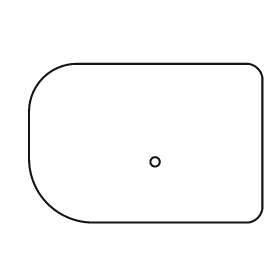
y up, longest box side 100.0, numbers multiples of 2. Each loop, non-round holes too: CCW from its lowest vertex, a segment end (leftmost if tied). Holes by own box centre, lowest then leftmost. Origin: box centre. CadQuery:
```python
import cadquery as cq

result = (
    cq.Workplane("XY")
    .moveTo(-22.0, -34.0)
    .lineTo(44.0, -34.0)
    .threePointArc((48.0, -32.0), (50.0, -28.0))
    .lineTo(50.0, 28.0)
    .threePointArc((48.0, 32.0), (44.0, 34.0))
    .lineTo(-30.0, 34.0)
    .threePointArc((-44.0, 28.0), (-50.0, 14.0))
    .lineTo(-50.0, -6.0)
    .threePointArc((-42.0, -26.0), (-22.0, -34.0))
    .close()
    .moveTo(4.0, -8.0)
    .circle(2.0)
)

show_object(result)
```